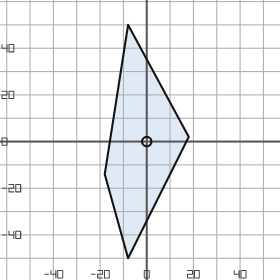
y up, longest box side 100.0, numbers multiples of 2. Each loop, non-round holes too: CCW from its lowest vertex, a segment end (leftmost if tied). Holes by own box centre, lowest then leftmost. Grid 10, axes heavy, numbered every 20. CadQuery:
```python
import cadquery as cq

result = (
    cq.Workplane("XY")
    .moveTo(-8.0, -50.0)
    .lineTo(18.0, 2.0)
    .lineTo(-8.0, 50.0)
    .lineTo(-18.0, -14.0)
    .close()
    .moveTo(0.0, 0.0)
    .circle(2.0)
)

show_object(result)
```